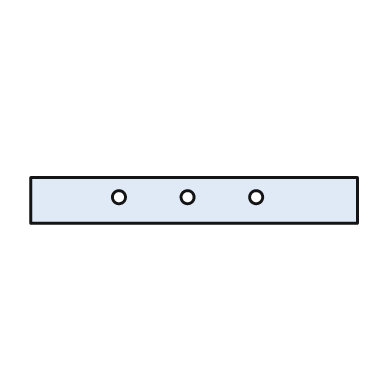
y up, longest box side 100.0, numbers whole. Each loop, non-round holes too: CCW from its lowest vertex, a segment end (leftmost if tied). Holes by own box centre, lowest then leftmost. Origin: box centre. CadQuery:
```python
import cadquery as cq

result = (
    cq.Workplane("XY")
    .moveTo(-50.0, -7.0)
    .lineTo(50.0, -7.0)
    .lineTo(50.0, 7.0)
    .lineTo(-50.0, 7.0)
    .close()
    .moveTo(-23.0, 1.0)
    .circle(2.0)
    .moveTo(-2.0, 1.0)
    .circle(2.0)
    .moveTo(19.0, 1.0)
    .circle(2.0)
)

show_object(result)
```